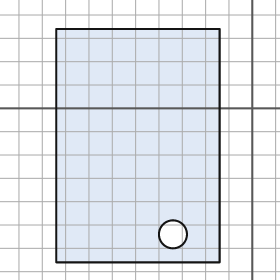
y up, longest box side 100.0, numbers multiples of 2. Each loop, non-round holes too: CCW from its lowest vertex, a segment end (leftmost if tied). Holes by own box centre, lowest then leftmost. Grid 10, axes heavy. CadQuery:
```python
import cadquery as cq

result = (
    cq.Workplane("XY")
    .moveTo(-84.0, -66.0)
    .lineTo(-14.0, -66.0)
    .lineTo(-14.0, 34.0)
    .lineTo(-84.0, 34.0)
    .close()
    .moveTo(-34.0, -54.0)
    .circle(6.0)
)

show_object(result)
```